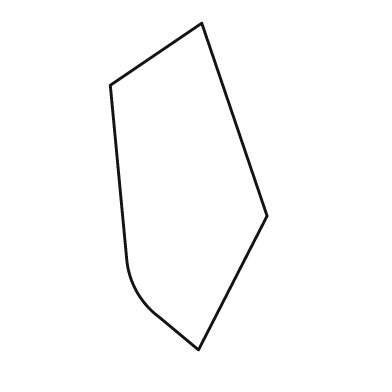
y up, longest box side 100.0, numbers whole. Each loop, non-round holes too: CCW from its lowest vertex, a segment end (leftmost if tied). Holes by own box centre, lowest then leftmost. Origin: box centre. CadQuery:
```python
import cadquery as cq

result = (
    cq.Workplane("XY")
    .moveTo(3.0, -50.0)
    .lineTo(24.0, -9.0)
    .lineTo(4.0, 50.0)
    .lineTo(-24.0, 31.0)
    .lineTo(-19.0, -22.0)
    .threePointArc((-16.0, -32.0), (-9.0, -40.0))
    .close()
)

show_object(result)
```